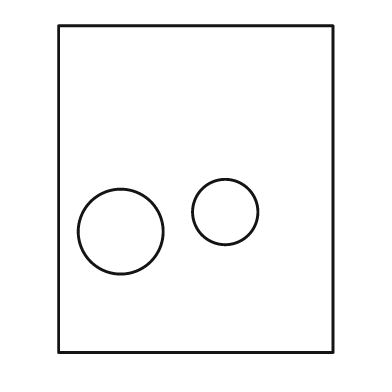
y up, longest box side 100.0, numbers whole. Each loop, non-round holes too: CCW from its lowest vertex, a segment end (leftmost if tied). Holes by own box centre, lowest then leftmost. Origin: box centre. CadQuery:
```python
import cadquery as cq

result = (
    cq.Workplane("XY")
    .moveTo(-42.0, -50.0)
    .lineTo(42.0, -50.0)
    .lineTo(42.0, 50.0)
    .lineTo(-42.0, 50.0)
    .close()
    .moveTo(-23.0, -13.0)
    .circle(13.0)
    .moveTo(9.0, -7.0)
    .circle(10.0)
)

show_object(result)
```